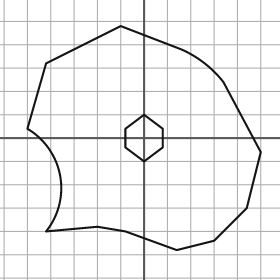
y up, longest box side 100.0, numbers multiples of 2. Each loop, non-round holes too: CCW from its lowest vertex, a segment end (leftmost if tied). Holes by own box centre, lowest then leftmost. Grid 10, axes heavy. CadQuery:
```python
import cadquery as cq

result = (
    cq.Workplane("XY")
    .moveTo(14.0, -48.0)
    .lineTo(30.0, -44.0)
    .lineTo(44.0, -30.0)
    .lineTo(50.0, -6.0)
    .lineTo(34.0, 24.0)
    .threePointArc((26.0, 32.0), (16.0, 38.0))
    .lineTo(-10.0, 48.0)
    .lineTo(-42.0, 32.0)
    .lineTo(-50.0, 4.0)
    .threePointArc((-36.0, -16.0), (-42.0, -40.0))
    .lineTo(-20.0, -38.0)
    .lineTo(-8.0, -40.0)
    .close()
    .moveTo(0.0, -10.0)
    .lineTo(8.0, -4.0)
    .lineTo(8.0, 4.0)
    .lineTo(0.0, 10.0)
    .lineTo(-8.0, 4.0)
    .lineTo(-8.0, -4.0)
    .close()
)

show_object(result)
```